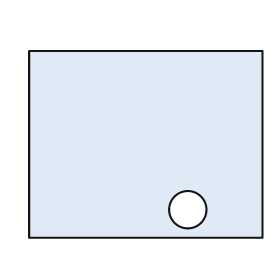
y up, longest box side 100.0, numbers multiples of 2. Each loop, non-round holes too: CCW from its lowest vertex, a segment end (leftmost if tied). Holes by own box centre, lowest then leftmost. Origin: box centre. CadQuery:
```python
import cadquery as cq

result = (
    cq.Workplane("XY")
    .moveTo(-50.0, -40.0)
    .lineTo(50.0, -40.0)
    .lineTo(50.0, 40.0)
    .lineTo(-50.0, 40.0)
    .close()
    .moveTo(18.0, -28.0)
    .circle(8.0)
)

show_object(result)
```